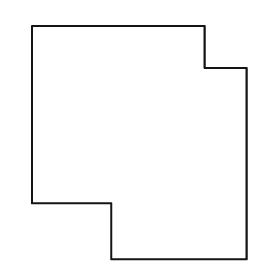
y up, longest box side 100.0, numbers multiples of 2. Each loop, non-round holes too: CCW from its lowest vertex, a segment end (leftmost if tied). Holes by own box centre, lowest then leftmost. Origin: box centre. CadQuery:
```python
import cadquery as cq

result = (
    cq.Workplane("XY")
    .moveTo(-12.0, -50.0)
    .lineTo(46.0, -50.0)
    .lineTo(46.0, 32.0)
    .lineTo(28.0, 32.0)
    .lineTo(28.0, 50.0)
    .lineTo(-46.0, 50.0)
    .lineTo(-46.0, -26.0)
    .lineTo(-12.0, -26.0)
    .close()
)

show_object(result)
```